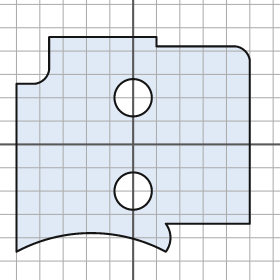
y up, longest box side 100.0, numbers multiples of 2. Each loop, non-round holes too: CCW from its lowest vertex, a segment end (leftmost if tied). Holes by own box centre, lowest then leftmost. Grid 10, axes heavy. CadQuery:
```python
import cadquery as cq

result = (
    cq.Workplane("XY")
    .moveTo(-50.0, -46.0)
    .threePointArc((-18.0, -38.0), (14.0, -46.0))
    .threePointArc((16.0, -40.0), (14.0, -34.0))
    .lineTo(50.0, -34.0)
    .lineTo(50.0, 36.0)
    .threePointArc((48.0, 40.0), (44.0, 42.0))
    .lineTo(10.0, 42.0)
    .lineTo(10.0, 46.0)
    .lineTo(-36.0, 46.0)
    .lineTo(-36.0, 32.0)
    .threePointArc((-38.0, 28.0), (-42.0, 26.0))
    .lineTo(-50.0, 26.0)
    .close()
    .moveTo(0.0, -20.0)
    .circle(8.0)
    .moveTo(0.0, 20.0)
    .circle(8.0)
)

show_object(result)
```